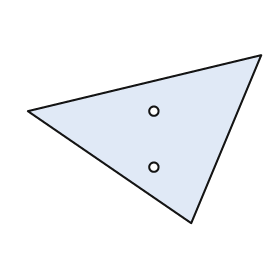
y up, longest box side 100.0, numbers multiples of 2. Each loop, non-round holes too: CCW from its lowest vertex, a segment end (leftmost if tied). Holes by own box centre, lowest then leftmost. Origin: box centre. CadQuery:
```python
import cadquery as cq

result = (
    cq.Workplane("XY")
    .moveTo(20.0, -36.0)
    .lineTo(50.0, 36.0)
    .lineTo(-50.0, 12.0)
    .close()
    .moveTo(4.0, -12.0)
    .circle(2.0)
    .moveTo(4.0, 12.0)
    .circle(2.0)
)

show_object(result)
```